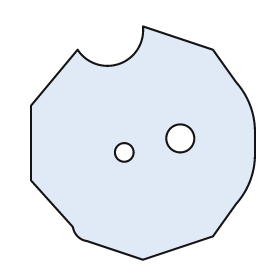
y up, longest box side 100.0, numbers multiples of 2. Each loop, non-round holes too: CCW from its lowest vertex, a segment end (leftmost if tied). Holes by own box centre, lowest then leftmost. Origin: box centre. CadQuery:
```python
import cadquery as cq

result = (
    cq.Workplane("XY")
    .moveTo(0.0, -50.0)
    .lineTo(30.0, -40.0)
    .lineTo(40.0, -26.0)
    .threePointArc((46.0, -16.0), (48.0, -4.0))
    .lineTo(48.0, 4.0)
    .threePointArc((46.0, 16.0), (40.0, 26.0))
    .lineTo(30.0, 40.0)
    .lineTo(0.0, 50.0)
    .threePointArc((-10.0, 34.0), (-28.0, 40.0))
    .lineTo(-48.0, 16.0)
    .lineTo(-48.0, -16.0)
    .lineTo(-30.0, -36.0)
    .threePointArc((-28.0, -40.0), (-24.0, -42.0))
    .close()
    .moveTo(-8.0, -4.0)
    .circle(4.0)
    .moveTo(16.0, 2.0)
    .circle(6.0)
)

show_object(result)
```